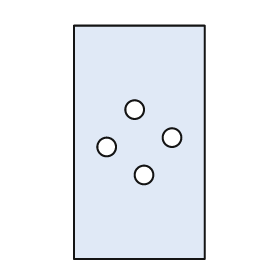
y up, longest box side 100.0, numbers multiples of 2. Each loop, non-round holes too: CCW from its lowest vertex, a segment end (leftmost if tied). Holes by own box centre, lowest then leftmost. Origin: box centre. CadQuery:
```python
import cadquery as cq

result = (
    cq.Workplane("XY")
    .moveTo(-28.0, -50.0)
    .lineTo(28.0, -50.0)
    .lineTo(28.0, 50.0)
    .lineTo(-28.0, 50.0)
    .close()
    .moveTo(2.0, -14.0)
    .circle(4.0)
    .moveTo(-14.0, -2.0)
    .circle(4.0)
    .moveTo(14.0, 2.0)
    .circle(4.0)
    .moveTo(-2.0, 14.0)
    .circle(4.0)
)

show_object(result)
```